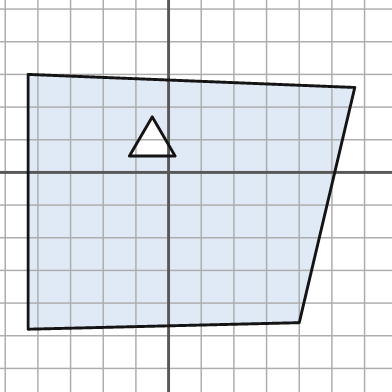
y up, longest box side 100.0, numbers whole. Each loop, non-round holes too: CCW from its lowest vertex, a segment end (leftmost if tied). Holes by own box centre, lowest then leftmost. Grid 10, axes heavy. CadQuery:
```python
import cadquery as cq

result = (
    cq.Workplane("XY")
    .moveTo(-43.0, -48.0)
    .lineTo(40.0, -46.0)
    .lineTo(57.0, 26.0)
    .lineTo(-43.0, 30.0)
    .close()
    .moveTo(-12.0, 5.0)
    .lineTo(2.0, 5.0)
    .lineTo(-5.0, 17.0)
    .close()
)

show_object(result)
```